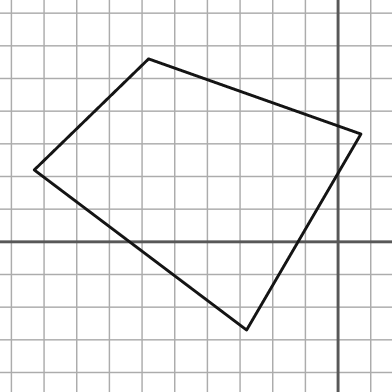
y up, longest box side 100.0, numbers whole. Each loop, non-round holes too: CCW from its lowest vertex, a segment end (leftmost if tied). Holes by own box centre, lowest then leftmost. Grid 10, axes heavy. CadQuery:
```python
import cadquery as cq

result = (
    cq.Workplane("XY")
    .moveTo(-28.0, -27.0)
    .lineTo(7.0, 33.0)
    .lineTo(-58.0, 56.0)
    .lineTo(-93.0, 22.0)
    .close()
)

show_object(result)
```